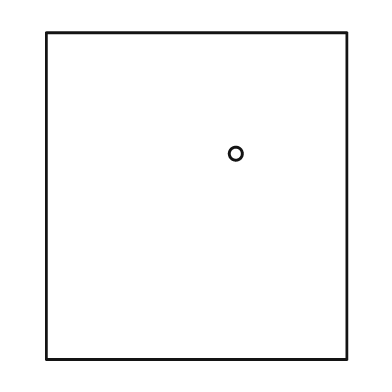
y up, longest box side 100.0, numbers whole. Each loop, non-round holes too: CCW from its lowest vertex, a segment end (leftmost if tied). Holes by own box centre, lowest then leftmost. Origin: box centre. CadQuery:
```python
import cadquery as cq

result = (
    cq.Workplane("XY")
    .moveTo(-46.0, -50.0)
    .lineTo(46.0, -50.0)
    .lineTo(46.0, 50.0)
    .lineTo(-46.0, 50.0)
    .close()
    .moveTo(12.0, 13.0)
    .circle(2.0)
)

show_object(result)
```